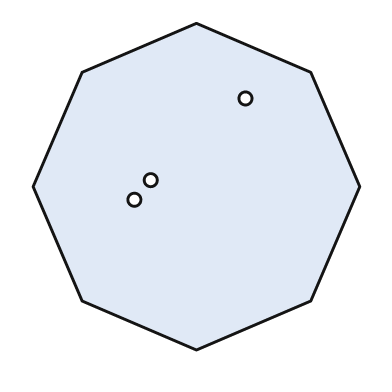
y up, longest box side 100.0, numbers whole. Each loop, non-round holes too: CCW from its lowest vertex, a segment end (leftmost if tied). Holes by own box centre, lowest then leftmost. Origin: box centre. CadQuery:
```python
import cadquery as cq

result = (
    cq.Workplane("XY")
    .moveTo(0.0, -50.0)
    .lineTo(35.0, -35.0)
    .lineTo(50.0, 0.0)
    .lineTo(35.0, 35.0)
    .lineTo(0.0, 50.0)
    .lineTo(-35.0, 35.0)
    .lineTo(-50.0, 0.0)
    .lineTo(-35.0, -35.0)
    .close()
    .moveTo(-19.0, -4.0)
    .circle(2.0)
    .moveTo(-14.0, 2.0)
    .circle(2.0)
    .moveTo(15.0, 27.0)
    .circle(2.0)
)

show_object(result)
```